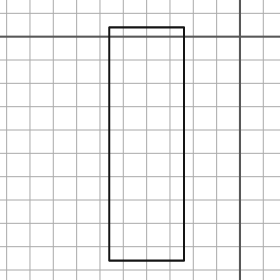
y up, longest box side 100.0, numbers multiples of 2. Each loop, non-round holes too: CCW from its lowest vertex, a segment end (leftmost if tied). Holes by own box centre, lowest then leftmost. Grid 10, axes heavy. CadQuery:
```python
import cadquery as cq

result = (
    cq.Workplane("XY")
    .moveTo(-56.0, -96.0)
    .lineTo(-24.0, -96.0)
    .lineTo(-24.0, 4.0)
    .lineTo(-56.0, 4.0)
    .close()
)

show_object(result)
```